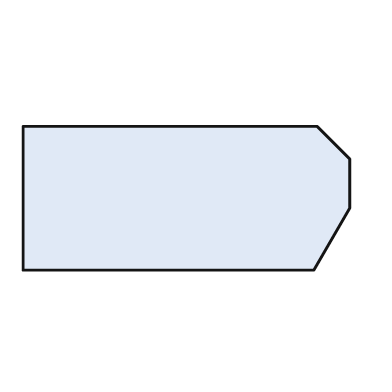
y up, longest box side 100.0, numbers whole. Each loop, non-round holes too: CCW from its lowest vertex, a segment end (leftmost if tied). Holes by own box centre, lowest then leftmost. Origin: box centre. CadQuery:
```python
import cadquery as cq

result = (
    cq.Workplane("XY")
    .moveTo(-50.0, -22.0)
    .lineTo(39.0, -22.0)
    .lineTo(50.0, -3.0)
    .lineTo(50.0, 12.0)
    .lineTo(40.0, 22.0)
    .lineTo(-50.0, 22.0)
    .close()
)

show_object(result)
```